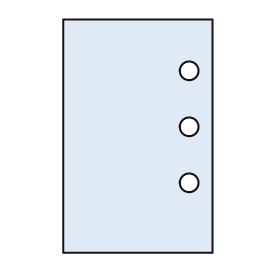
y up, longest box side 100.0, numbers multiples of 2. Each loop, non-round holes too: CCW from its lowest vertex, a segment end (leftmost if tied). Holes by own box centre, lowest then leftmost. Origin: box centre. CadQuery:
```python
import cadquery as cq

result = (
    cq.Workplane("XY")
    .moveTo(-32.0, -50.0)
    .lineTo(32.0, -50.0)
    .lineTo(32.0, 50.0)
    .lineTo(-32.0, 50.0)
    .close()
    .moveTo(22.0, -20.0)
    .circle(4.0)
    .moveTo(22.0, 4.0)
    .circle(4.0)
    .moveTo(22.0, 28.0)
    .circle(4.0)
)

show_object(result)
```